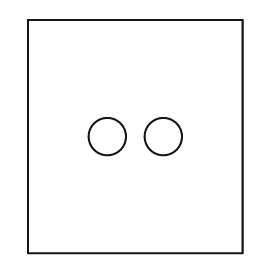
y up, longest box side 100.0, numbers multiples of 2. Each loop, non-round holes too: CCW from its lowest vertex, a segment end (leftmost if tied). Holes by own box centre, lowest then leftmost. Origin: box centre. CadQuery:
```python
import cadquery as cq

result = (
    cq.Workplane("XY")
    .moveTo(-46.0, -50.0)
    .lineTo(46.0, -50.0)
    .lineTo(46.0, 50.0)
    .lineTo(-46.0, 50.0)
    .close()
    .moveTo(-12.0, 0.0)
    .circle(8.0)
    .moveTo(12.0, 0.0)
    .circle(8.0)
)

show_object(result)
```